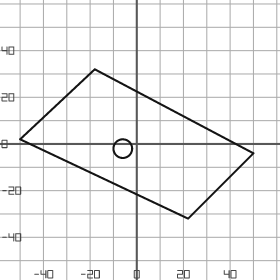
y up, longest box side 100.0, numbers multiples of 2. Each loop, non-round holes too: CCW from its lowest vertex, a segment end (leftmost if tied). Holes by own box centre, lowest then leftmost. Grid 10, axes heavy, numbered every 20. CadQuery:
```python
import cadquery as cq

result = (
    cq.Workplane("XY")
    .moveTo(22.0, -32.0)
    .lineTo(50.0, -4.0)
    .lineTo(-18.0, 32.0)
    .lineTo(-50.0, 2.0)
    .close()
    .moveTo(-6.0, -2.0)
    .circle(4.0)
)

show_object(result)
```